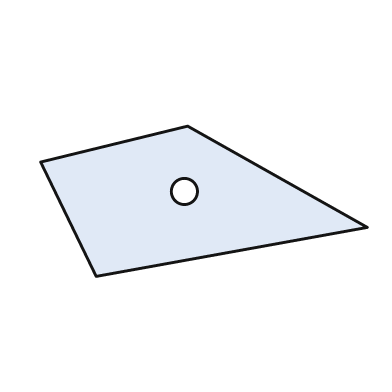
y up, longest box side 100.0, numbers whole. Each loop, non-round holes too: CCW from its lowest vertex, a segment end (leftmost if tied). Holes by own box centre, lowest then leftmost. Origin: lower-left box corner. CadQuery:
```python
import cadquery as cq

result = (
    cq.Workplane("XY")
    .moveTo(17.0, 0.0)
    .lineTo(100.0, 15.0)
    .lineTo(45.0, 46.0)
    .lineTo(0.0, 35.0)
    .close()
    .moveTo(44.0, 26.0)
    .circle(4.0)
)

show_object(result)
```